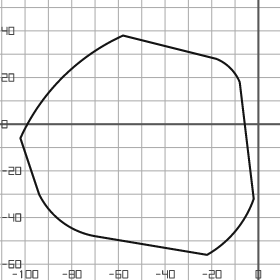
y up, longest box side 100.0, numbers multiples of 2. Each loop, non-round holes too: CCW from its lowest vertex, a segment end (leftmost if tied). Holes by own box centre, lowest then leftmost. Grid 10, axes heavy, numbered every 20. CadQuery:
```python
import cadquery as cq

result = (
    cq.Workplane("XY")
    .moveTo(-22.0, -56.0)
    .threePointArc((-10.0, -46.0), (-2.0, -32.0))
    .lineTo(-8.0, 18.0)
    .threePointArc((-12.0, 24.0), (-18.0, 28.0))
    .lineTo(-58.0, 38.0)
    .threePointArc((-84.0, 20.0), (-102.0, -6.0))
    .lineTo(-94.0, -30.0)
    .threePointArc((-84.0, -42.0), (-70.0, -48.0))
    .close()
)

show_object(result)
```